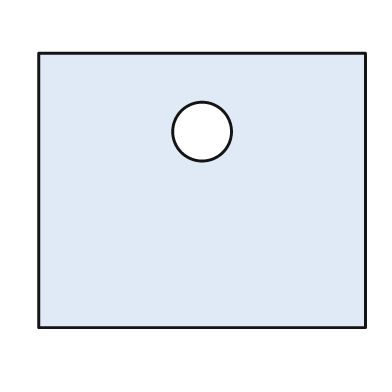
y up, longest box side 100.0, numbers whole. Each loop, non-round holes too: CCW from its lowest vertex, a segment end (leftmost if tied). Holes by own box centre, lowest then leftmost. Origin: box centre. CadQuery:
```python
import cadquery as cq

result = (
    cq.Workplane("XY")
    .moveTo(-50.0, -42.0)
    .lineTo(50.0, -42.0)
    .lineTo(50.0, 42.0)
    .lineTo(-50.0, 42.0)
    .close()
    .moveTo(0.0, 18.0)
    .circle(9.0)
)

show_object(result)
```